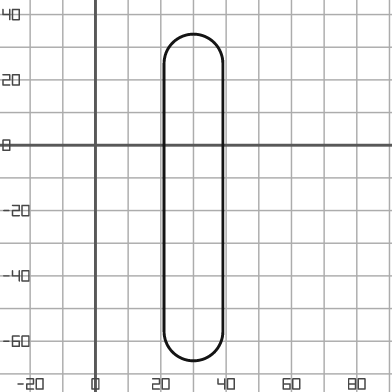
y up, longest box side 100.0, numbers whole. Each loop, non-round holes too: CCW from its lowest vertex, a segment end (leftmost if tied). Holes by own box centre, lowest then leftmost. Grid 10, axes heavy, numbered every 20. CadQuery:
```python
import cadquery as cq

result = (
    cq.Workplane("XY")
    .moveTo(21.0, -57.0)
    .threePointArc((30.0, -66.0), (39.0, -57.0))
    .lineTo(39.0, 25.0)
    .threePointArc((30.0, 34.0), (21.0, 25.0))
    .close()
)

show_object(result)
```